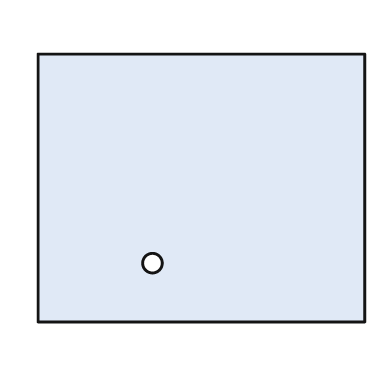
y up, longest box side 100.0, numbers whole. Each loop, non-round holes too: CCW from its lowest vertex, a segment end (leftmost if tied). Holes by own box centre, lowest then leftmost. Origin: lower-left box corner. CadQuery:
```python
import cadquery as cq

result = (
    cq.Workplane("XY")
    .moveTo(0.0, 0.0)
    .lineTo(100.0, 0.0)
    .lineTo(100.0, 82.0)
    .lineTo(0.0, 82.0)
    .close()
    .moveTo(35.0, 18.0)
    .circle(3.0)
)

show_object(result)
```